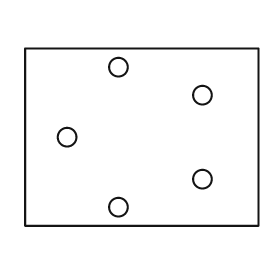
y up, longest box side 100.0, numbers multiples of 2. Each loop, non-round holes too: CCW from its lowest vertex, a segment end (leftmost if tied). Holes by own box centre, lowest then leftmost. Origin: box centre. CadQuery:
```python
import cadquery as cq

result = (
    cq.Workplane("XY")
    .moveTo(-50.0, -38.0)
    .lineTo(50.0, -38.0)
    .lineTo(50.0, 38.0)
    .lineTo(-50.0, 38.0)
    .close()
    .moveTo(-10.0, -30.0)
    .circle(4.0)
    .moveTo(26.0, -18.0)
    .circle(4.0)
    .moveTo(-32.0, 0.0)
    .circle(4.0)
    .moveTo(26.0, 18.0)
    .circle(4.0)
    .moveTo(-10.0, 30.0)
    .circle(4.0)
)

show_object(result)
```